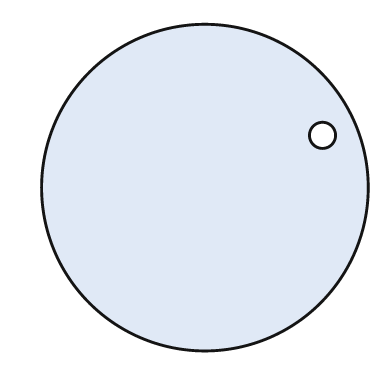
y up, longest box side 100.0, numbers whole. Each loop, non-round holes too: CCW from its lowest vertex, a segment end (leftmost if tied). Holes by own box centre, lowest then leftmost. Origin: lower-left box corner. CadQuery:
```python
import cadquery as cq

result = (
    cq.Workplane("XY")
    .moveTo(50.0, 50.0)
    .circle(50.0)
    .moveTo(86.0, 66.0)
    .circle(4.0)
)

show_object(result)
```